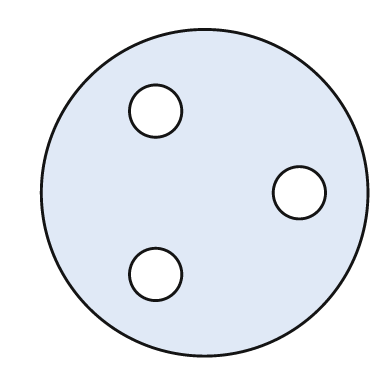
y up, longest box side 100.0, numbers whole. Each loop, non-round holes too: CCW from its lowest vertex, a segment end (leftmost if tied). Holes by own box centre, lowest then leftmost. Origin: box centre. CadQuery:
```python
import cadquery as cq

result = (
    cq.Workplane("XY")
    .moveTo(0.0, 0.0)
    .circle(50.0)
    .moveTo(-15.0, -25.0)
    .circle(8.0)
    .moveTo(29.0, 0.0)
    .circle(8.0)
    .moveTo(-15.0, 25.0)
    .circle(8.0)
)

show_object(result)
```